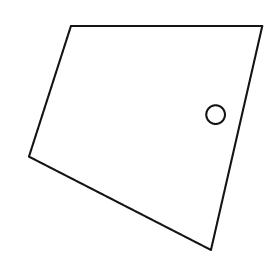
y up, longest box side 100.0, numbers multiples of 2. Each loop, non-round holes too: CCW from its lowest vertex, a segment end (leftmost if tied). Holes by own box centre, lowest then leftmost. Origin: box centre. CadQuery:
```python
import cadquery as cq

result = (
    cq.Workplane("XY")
    .moveTo(28.0, -48.0)
    .lineTo(50.0, 48.0)
    .lineTo(-32.0, 48.0)
    .lineTo(-50.0, -8.0)
    .close()
    .moveTo(30.0, 10.0)
    .circle(4.0)
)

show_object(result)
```